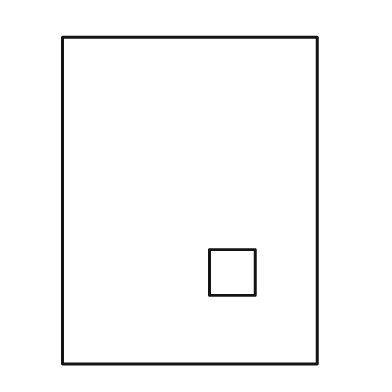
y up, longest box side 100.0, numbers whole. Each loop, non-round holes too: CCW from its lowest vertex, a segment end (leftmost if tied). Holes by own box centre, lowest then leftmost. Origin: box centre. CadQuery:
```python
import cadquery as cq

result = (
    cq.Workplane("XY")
    .moveTo(-39.0, -50.0)
    .lineTo(39.0, -50.0)
    .lineTo(39.0, 50.0)
    .lineTo(-39.0, 50.0)
    .close()
    .moveTo(6.0, -29.0)
    .lineTo(20.0, -29.0)
    .lineTo(20.0, -15.0)
    .lineTo(6.0, -15.0)
    .close()
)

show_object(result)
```